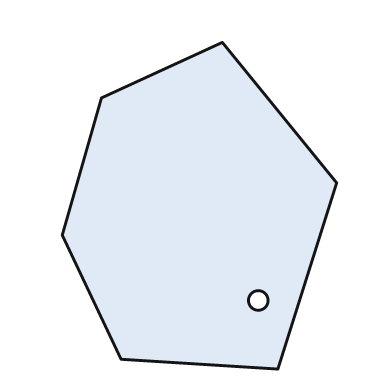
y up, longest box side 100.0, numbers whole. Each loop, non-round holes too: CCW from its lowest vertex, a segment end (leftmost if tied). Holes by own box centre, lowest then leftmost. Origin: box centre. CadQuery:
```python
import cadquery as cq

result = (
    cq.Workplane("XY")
    .moveTo(24.0, -50.0)
    .lineTo(42.0, 7.0)
    .lineTo(7.0, 50.0)
    .lineTo(-30.0, 33.0)
    .lineTo(-42.0, -9.0)
    .lineTo(-24.0, -47.0)
    .close()
    .moveTo(18.0, -29.0)
    .circle(3.0)
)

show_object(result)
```